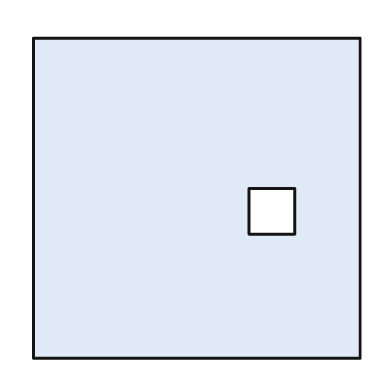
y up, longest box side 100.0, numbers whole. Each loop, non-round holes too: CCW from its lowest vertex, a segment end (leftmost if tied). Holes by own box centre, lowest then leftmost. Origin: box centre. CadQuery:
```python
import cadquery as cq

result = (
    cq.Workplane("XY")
    .moveTo(-50.0, -49.0)
    .lineTo(50.0, -49.0)
    .lineTo(50.0, 49.0)
    .lineTo(-50.0, 49.0)
    .close()
    .moveTo(16.0, -11.0)
    .lineTo(30.0, -11.0)
    .lineTo(30.0, 3.0)
    .lineTo(16.0, 3.0)
    .close()
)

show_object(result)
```